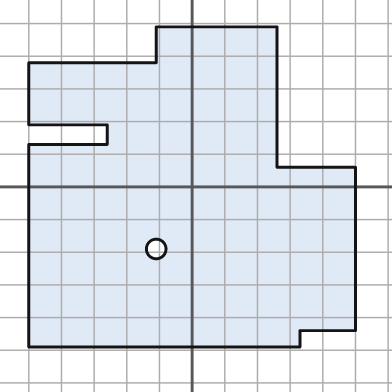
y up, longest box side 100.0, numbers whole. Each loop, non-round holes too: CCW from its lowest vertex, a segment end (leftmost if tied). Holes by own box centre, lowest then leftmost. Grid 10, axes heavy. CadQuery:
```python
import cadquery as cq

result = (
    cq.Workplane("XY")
    .moveTo(-50.0, -49.0)
    .lineTo(33.0, -49.0)
    .lineTo(33.0, -44.0)
    .lineTo(50.0, -44.0)
    .lineTo(50.0, 6.0)
    .lineTo(26.0, 6.0)
    .lineTo(26.0, 49.0)
    .lineTo(-11.0, 49.0)
    .lineTo(-11.0, 38.0)
    .lineTo(-50.0, 38.0)
    .lineTo(-50.0, 19.0)
    .lineTo(-26.0, 19.0)
    .lineTo(-26.0, 13.0)
    .lineTo(-50.0, 13.0)
    .close()
    .moveTo(-11.0, -19.0)
    .circle(3.0)
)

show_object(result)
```